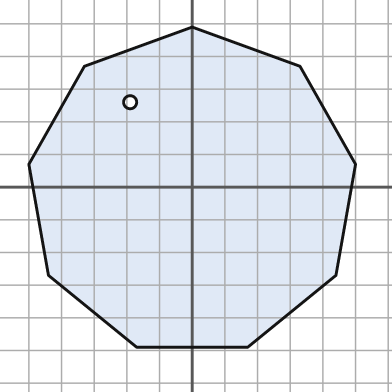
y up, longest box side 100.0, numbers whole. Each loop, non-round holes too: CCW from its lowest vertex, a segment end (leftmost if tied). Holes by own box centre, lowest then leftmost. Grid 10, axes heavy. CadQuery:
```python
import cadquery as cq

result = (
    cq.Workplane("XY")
    .moveTo(-17.0, -49.0)
    .lineTo(17.0, -49.0)
    .lineTo(44.0, -27.0)
    .lineTo(50.0, 7.0)
    .lineTo(33.0, 37.0)
    .lineTo(0.0, 49.0)
    .lineTo(-33.0, 37.0)
    .lineTo(-50.0, 7.0)
    .lineTo(-44.0, -27.0)
    .close()
    .moveTo(-19.0, 26.0)
    .circle(2.0)
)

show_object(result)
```